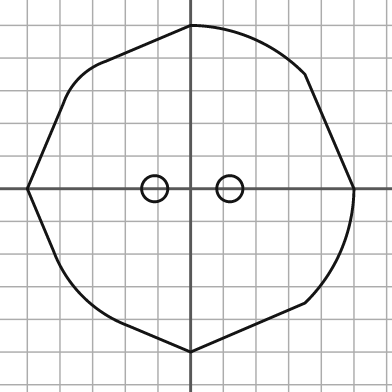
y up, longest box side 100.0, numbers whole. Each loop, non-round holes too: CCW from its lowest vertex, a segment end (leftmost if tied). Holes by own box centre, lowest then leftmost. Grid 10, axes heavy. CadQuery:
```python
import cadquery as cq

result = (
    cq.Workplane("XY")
    .moveTo(0.0, -50.0)
    .lineTo(35.0, -35.0)
    .threePointArc((46.0, -19.0), (50.0, 0.0))
    .lineTo(35.0, 35.0)
    .threePointArc((19.0, 46.0), (0.0, 50.0))
    .lineTo(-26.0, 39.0)
    .threePointArc((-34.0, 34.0), (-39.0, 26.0))
    .lineTo(-50.0, 0.0)
    .lineTo(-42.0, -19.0)
    .threePointArc((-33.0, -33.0), (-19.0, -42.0))
    .close()
    .moveTo(-11.0, 0.0)
    .circle(4.0)
    .moveTo(12.0, 0.0)
    .circle(4.0)
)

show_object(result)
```